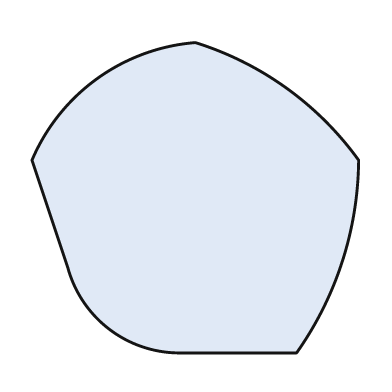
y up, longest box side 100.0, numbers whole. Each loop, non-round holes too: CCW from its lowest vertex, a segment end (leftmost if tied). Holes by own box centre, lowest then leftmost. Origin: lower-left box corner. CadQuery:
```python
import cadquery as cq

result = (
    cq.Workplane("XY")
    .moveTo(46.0, 0.0)
    .lineTo(81.0, 0.0)
    .threePointArc((95.0, 28.0), (100.0, 59.0))
    .threePointArc((78.0, 81.0), (50.0, 95.0))
    .threePointArc((20.0, 84.0), (0.0, 59.0))
    .lineTo(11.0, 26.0)
    .threePointArc((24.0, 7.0), (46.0, 0.0))
    .close()
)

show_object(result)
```